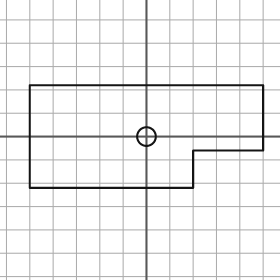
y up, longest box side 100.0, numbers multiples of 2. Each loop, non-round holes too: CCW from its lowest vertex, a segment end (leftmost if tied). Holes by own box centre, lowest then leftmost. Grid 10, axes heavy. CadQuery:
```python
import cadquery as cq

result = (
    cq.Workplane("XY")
    .moveTo(-50.0, -22.0)
    .lineTo(20.0, -22.0)
    .lineTo(20.0, -6.0)
    .lineTo(50.0, -6.0)
    .lineTo(50.0, 22.0)
    .lineTo(-50.0, 22.0)
    .close()
    .moveTo(0.0, 0.0)
    .circle(4.0)
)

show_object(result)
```